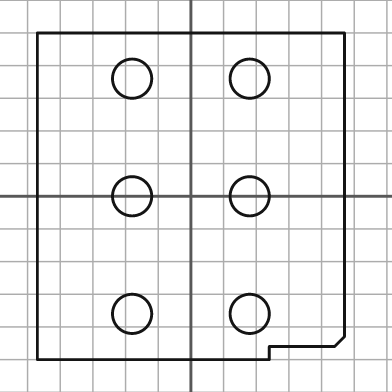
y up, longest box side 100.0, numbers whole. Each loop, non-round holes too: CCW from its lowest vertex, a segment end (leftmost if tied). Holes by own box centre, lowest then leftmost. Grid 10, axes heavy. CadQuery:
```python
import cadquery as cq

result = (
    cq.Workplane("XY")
    .moveTo(-47.0, -50.0)
    .lineTo(24.0, -50.0)
    .lineTo(24.0, -46.0)
    .lineTo(44.0, -46.0)
    .lineTo(47.0, -43.0)
    .lineTo(47.0, 50.0)
    .lineTo(-47.0, 50.0)
    .close()
    .moveTo(-18.0, -36.0)
    .circle(6.0)
    .moveTo(18.0, -36.0)
    .circle(6.0)
    .moveTo(-18.0, 0.0)
    .circle(6.0)
    .moveTo(18.0, 0.0)
    .circle(6.0)
    .moveTo(-18.0, 36.0)
    .circle(6.0)
    .moveTo(18.0, 36.0)
    .circle(6.0)
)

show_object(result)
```